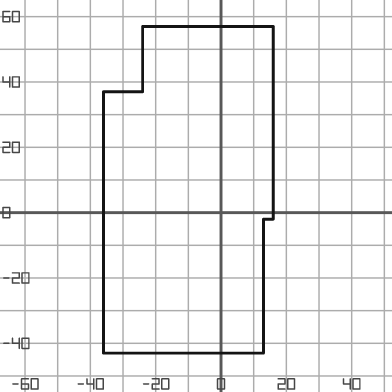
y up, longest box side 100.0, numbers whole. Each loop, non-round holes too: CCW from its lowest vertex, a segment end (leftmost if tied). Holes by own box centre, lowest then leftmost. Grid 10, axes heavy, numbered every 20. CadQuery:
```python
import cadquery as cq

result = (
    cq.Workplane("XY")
    .moveTo(-36.0, -43.0)
    .lineTo(13.0, -43.0)
    .lineTo(13.0, -2.0)
    .lineTo(16.0, -2.0)
    .lineTo(16.0, 57.0)
    .lineTo(-24.0, 57.0)
    .lineTo(-24.0, 37.0)
    .lineTo(-36.0, 37.0)
    .close()
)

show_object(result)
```